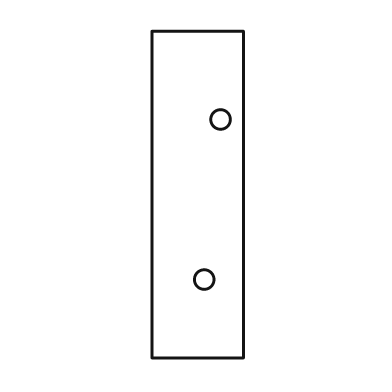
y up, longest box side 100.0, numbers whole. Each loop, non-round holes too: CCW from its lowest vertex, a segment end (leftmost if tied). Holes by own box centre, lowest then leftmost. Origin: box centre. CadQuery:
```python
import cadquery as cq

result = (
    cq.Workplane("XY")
    .moveTo(-14.0, -50.0)
    .lineTo(14.0, -50.0)
    .lineTo(14.0, 50.0)
    .lineTo(-14.0, 50.0)
    .close()
    .moveTo(2.0, -26.0)
    .circle(3.0)
    .moveTo(7.0, 23.0)
    .circle(3.0)
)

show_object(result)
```